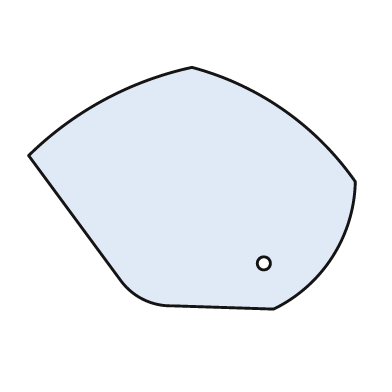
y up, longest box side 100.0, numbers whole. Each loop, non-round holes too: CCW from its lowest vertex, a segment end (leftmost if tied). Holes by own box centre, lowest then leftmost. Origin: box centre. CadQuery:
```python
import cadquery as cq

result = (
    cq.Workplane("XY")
    .moveTo(25.0, -37.0)
    .threePointArc((43.0, -21.0), (50.0, 2.0))
    .threePointArc((28.0, 24.0), (0.0, 37.0))
    .threePointArc((-27.0, 27.0), (-50.0, 10.0))
    .lineTo(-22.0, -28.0)
    .threePointArc((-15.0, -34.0), (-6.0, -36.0))
    .close()
    .moveTo(22.0, -23.0)
    .circle(2.0)
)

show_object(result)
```